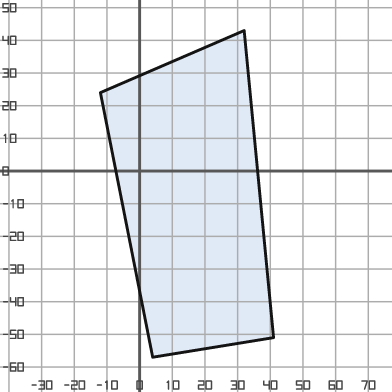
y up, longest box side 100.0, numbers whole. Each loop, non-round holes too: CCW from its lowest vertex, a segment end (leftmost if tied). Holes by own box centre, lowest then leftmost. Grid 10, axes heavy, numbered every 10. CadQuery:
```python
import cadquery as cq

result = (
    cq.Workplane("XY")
    .moveTo(4.0, -57.0)
    .lineTo(41.0, -51.0)
    .lineTo(32.0, 43.0)
    .lineTo(-12.0, 24.0)
    .close()
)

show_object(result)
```